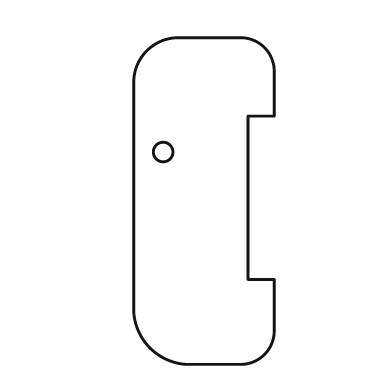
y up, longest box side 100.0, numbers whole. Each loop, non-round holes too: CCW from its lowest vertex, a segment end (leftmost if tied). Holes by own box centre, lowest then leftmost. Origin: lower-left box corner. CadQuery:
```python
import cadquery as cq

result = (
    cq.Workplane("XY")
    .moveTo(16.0, 0.0)
    .lineTo(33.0, 0.0)
    .threePointArc((40.0, 3.0), (43.0, 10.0))
    .lineTo(43.0, 26.0)
    .lineTo(35.0, 26.0)
    .lineTo(35.0, 76.0)
    .lineTo(43.0, 76.0)
    .lineTo(43.0, 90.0)
    .threePointArc((40.0, 97.0), (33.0, 100.0))
    .lineTo(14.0, 100.0)
    .threePointArc((4.0, 96.0), (0.0, 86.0))
    .lineTo(0.0, 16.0)
    .threePointArc((5.0, 5.0), (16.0, 0.0))
    .close()
    .moveTo(9.0, 65.0)
    .circle(3.0)
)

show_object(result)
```